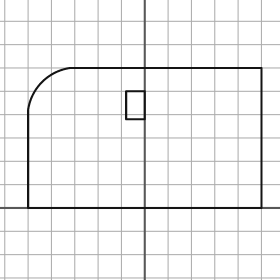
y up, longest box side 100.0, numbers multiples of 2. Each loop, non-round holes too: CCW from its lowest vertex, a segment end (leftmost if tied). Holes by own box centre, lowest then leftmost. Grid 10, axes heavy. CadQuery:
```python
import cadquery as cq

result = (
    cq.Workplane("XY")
    .moveTo(-50.0, 0.0)
    .lineTo(50.0, 0.0)
    .lineTo(50.0, 60.0)
    .lineTo(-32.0, 60.0)
    .threePointArc((-44.0, 54.0), (-50.0, 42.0))
    .close()
    .moveTo(-8.0, 38.0)
    .lineTo(0.0, 38.0)
    .lineTo(0.0, 50.0)
    .lineTo(-8.0, 50.0)
    .close()
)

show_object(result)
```